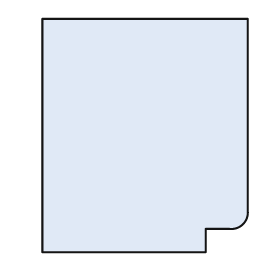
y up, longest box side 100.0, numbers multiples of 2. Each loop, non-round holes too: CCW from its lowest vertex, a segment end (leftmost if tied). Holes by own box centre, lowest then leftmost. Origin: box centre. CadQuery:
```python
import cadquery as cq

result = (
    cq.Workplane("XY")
    .moveTo(-44.0, -50.0)
    .lineTo(26.0, -50.0)
    .lineTo(26.0, -40.0)
    .lineTo(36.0, -40.0)
    .threePointArc((42.0, -38.0), (44.0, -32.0))
    .lineTo(44.0, 50.0)
    .lineTo(-44.0, 50.0)
    .close()
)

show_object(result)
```